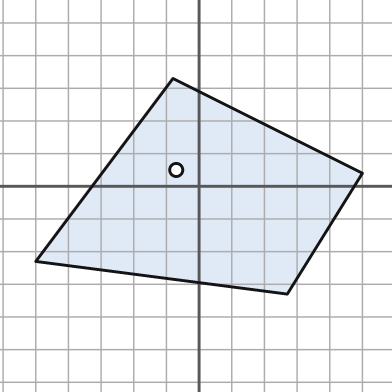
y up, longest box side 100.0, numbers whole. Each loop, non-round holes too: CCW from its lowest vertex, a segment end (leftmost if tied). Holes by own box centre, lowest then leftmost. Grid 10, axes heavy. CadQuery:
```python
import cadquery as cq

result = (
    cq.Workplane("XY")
    .moveTo(27.0, -33.0)
    .lineTo(50.0, 4.0)
    .lineTo(-8.0, 33.0)
    .lineTo(-50.0, -23.0)
    .close()
    .moveTo(-7.0, 5.0)
    .circle(2.0)
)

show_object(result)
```